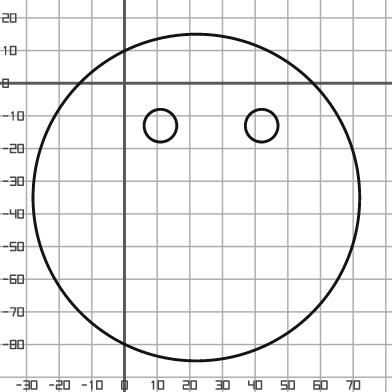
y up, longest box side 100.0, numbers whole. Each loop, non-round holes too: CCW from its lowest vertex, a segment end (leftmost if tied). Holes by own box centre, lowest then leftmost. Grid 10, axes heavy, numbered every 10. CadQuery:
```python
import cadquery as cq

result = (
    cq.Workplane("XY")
    .moveTo(22.0, -35.0)
    .circle(50.0)
    .moveTo(11.0, -13.0)
    .circle(5.0)
    .moveTo(42.0, -13.0)
    .circle(5.0)
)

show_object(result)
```